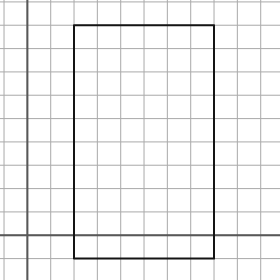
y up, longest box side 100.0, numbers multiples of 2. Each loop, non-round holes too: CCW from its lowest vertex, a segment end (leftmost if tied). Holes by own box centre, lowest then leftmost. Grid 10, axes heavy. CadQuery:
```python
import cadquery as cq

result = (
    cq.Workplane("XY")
    .moveTo(20.0, -10.0)
    .lineTo(80.0, -10.0)
    .lineTo(80.0, 90.0)
    .lineTo(20.0, 90.0)
    .close()
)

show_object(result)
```